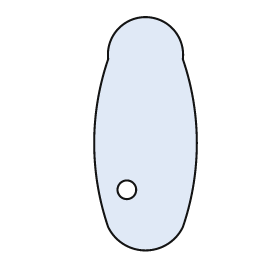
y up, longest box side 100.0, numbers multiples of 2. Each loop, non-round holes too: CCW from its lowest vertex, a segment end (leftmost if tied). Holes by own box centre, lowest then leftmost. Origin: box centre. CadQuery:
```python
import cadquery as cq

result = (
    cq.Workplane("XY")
    .moveTo(-16.0, -40.0)
    .threePointArc((0.0, -50.0), (16.0, -40.0))
    .threePointArc((22.0, -4.0), (16.0, 32.0))
    .threePointArc((0.0, 50.0), (-16.0, 32.0))
    .threePointArc((-22.0, -4.0), (-16.0, -40.0))
    .close()
    .moveTo(-8.0, -24.0)
    .circle(4.0)
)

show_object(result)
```